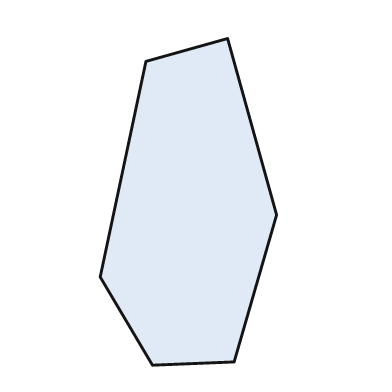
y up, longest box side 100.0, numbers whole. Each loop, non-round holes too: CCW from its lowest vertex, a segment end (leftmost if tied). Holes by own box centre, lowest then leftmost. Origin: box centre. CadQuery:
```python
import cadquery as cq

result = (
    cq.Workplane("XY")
    .moveTo(-11.0, -50.0)
    .lineTo(14.0, -49.0)
    .lineTo(27.0, -4.0)
    .lineTo(12.0, 50.0)
    .lineTo(-13.0, 43.0)
    .lineTo(-27.0, -23.0)
    .close()
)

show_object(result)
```